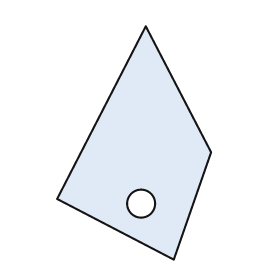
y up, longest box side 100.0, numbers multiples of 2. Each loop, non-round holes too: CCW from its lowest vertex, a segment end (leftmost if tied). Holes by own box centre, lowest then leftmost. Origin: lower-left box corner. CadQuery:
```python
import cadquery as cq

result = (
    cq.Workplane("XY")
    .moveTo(50.0, 0.0)
    .lineTo(66.0, 46.0)
    .lineTo(38.0, 100.0)
    .lineTo(0.0, 26.0)
    .close()
    .moveTo(36.0, 24.0)
    .circle(6.0)
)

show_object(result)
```